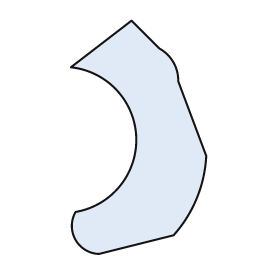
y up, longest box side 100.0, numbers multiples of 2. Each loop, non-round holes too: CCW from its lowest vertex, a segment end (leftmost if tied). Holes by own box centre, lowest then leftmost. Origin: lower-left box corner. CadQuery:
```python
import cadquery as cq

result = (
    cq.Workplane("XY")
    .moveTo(12.0, 0.0)
    .lineTo(44.0, 8.0)
    .threePointArc((54.0, 24.0), (58.0, 42.0))
    .lineTo(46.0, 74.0)
    .threePointArc((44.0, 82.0), (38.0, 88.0))
    .lineTo(26.0, 100.0)
    .lineTo(0.0, 80.0)
    .threePointArc((28.0, 50.0), (2.0, 18.0))
    .threePointArc((2.0, 6.0), (12.0, 0.0))
    .close()
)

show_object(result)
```